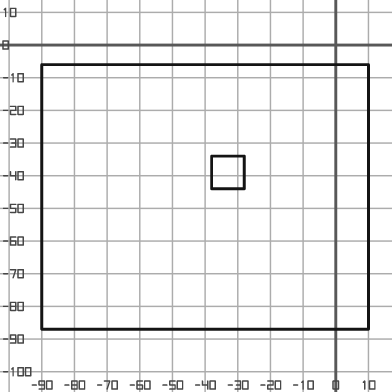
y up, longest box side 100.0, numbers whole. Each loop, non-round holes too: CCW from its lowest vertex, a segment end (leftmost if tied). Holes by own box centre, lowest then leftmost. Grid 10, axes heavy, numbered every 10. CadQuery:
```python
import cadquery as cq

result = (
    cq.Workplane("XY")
    .moveTo(-90.0, -87.0)
    .lineTo(10.0, -87.0)
    .lineTo(10.0, -6.0)
    .lineTo(-90.0, -6.0)
    .close()
    .moveTo(-38.0, -44.0)
    .lineTo(-28.0, -44.0)
    .lineTo(-28.0, -34.0)
    .lineTo(-38.0, -34.0)
    .close()
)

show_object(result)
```